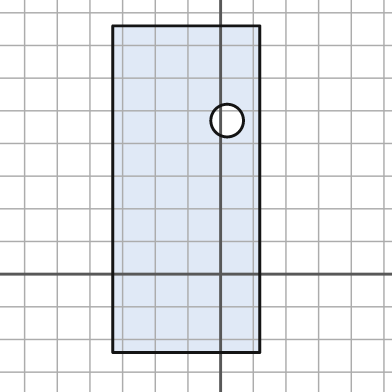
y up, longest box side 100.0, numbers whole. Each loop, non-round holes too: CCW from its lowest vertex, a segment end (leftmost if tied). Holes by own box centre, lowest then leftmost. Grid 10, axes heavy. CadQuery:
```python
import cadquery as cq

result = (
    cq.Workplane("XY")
    .moveTo(-33.0, -24.0)
    .lineTo(12.0, -24.0)
    .lineTo(12.0, 76.0)
    .lineTo(-33.0, 76.0)
    .close()
    .moveTo(2.0, 47.0)
    .circle(5.0)
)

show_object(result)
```